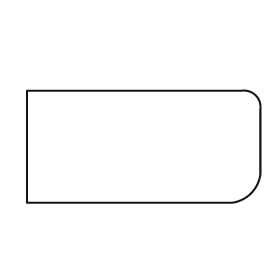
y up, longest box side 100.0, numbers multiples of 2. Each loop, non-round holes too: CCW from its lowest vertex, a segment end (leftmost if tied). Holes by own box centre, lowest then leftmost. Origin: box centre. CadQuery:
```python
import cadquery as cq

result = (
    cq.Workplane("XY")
    .moveTo(-50.0, -24.0)
    .lineTo(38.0, -24.0)
    .threePointArc((46.0, -20.0), (50.0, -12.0))
    .lineTo(50.0, 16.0)
    .threePointArc((48.0, 22.0), (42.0, 24.0))
    .lineTo(-50.0, 24.0)
    .close()
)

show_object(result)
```